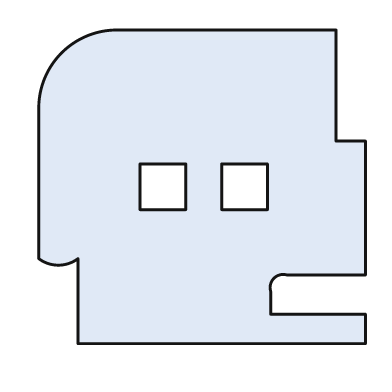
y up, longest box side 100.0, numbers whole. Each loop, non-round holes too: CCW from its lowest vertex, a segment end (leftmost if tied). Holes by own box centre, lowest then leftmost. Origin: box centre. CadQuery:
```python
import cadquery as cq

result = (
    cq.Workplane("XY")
    .moveTo(-38.0, -48.0)
    .lineTo(50.0, -48.0)
    .lineTo(50.0, -39.0)
    .lineTo(21.0, -39.0)
    .lineTo(21.0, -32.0)
    .threePointArc((22.0, -28.0), (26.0, -27.0))
    .lineTo(50.0, -27.0)
    .lineTo(50.0, 14.0)
    .lineTo(41.0, 14.0)
    .lineTo(41.0, 48.0)
    .lineTo(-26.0, 48.0)
    .threePointArc((-43.0, 41.0), (-50.0, 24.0))
    .lineTo(-50.0, -22.0)
    .threePointArc((-44.0, -24.0), (-38.0, -22.0))
    .close()
    .moveTo(-19.0, -7.0)
    .lineTo(-5.0, -7.0)
    .lineTo(-5.0, 7.0)
    .lineTo(-19.0, 7.0)
    .close()
    .moveTo(6.0, -7.0)
    .lineTo(20.0, -7.0)
    .lineTo(20.0, 7.0)
    .lineTo(6.0, 7.0)
    .close()
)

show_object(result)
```